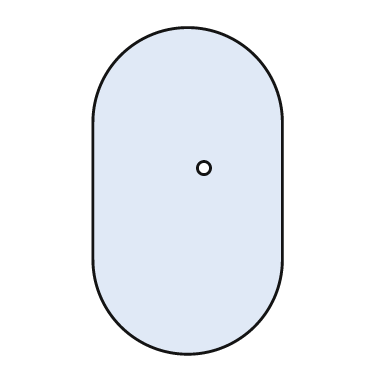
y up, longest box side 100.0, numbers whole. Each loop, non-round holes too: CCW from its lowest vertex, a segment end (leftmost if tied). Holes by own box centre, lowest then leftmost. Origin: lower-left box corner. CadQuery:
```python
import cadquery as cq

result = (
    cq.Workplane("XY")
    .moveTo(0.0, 29.0)
    .threePointArc((29.0, 0.0), (58.0, 29.0))
    .lineTo(58.0, 71.0)
    .threePointArc((29.0, 100.0), (0.0, 71.0))
    .close()
    .moveTo(34.0, 57.0)
    .circle(2.0)
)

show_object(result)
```